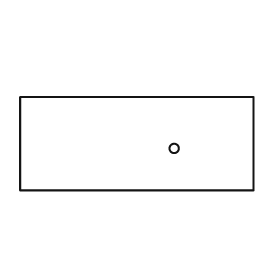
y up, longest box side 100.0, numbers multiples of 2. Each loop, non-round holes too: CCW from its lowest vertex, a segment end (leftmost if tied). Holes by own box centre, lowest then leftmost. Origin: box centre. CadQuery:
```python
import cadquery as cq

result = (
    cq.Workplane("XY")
    .moveTo(-50.0, -20.0)
    .lineTo(50.0, -20.0)
    .lineTo(50.0, 20.0)
    .lineTo(-50.0, 20.0)
    .close()
    .moveTo(16.0, -2.0)
    .circle(2.0)
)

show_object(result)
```